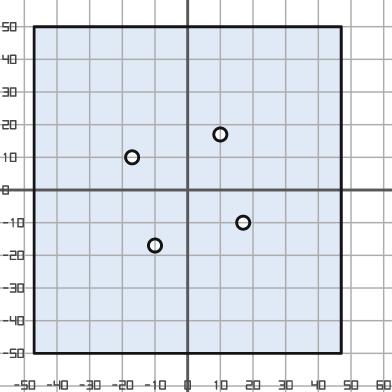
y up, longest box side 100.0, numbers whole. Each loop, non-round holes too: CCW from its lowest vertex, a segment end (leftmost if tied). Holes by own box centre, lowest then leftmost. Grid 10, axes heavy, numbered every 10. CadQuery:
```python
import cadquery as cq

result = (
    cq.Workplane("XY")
    .moveTo(-47.0, -50.0)
    .lineTo(47.0, -50.0)
    .lineTo(47.0, 50.0)
    .lineTo(-47.0, 50.0)
    .close()
    .moveTo(-10.0, -17.0)
    .circle(2.0)
    .moveTo(17.0, -10.0)
    .circle(2.0)
    .moveTo(-17.0, 10.0)
    .circle(2.0)
    .moveTo(10.0, 17.0)
    .circle(2.0)
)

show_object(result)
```